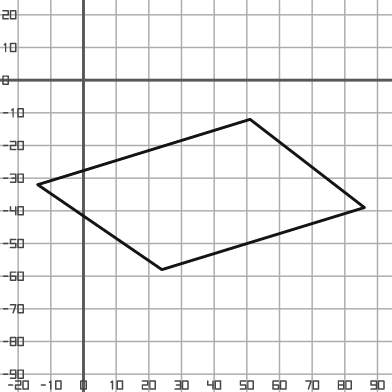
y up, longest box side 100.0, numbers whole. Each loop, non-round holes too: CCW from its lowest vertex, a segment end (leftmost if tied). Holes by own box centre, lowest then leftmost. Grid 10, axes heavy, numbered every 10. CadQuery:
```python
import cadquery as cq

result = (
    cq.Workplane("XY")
    .moveTo(24.0, -58.0)
    .lineTo(86.0, -39.0)
    .lineTo(51.0, -12.0)
    .lineTo(-14.0, -32.0)
    .close()
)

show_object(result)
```